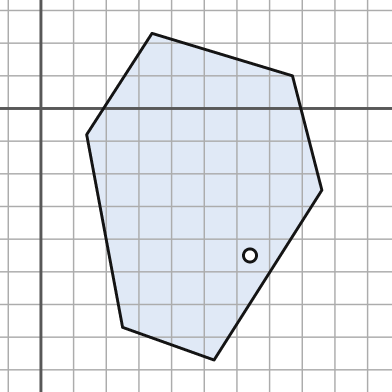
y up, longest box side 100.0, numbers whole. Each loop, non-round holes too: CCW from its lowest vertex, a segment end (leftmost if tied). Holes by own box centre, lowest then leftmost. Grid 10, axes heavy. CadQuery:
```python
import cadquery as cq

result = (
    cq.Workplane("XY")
    .moveTo(53.0, -77.0)
    .lineTo(86.0, -25.0)
    .lineTo(77.0, 10.0)
    .lineTo(34.0, 23.0)
    .lineTo(14.0, -8.0)
    .lineTo(25.0, -67.0)
    .close()
    .moveTo(64.0, -45.0)
    .circle(2.0)
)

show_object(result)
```